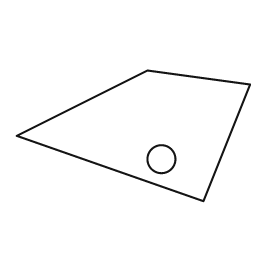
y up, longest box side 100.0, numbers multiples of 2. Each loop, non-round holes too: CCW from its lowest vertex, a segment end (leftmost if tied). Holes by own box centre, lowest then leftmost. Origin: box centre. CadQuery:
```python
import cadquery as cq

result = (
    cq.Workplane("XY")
    .moveTo(30.0, -28.0)
    .lineTo(50.0, 22.0)
    .lineTo(6.0, 28.0)
    .lineTo(-50.0, 0.0)
    .close()
    .moveTo(12.0, -10.0)
    .circle(6.0)
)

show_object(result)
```